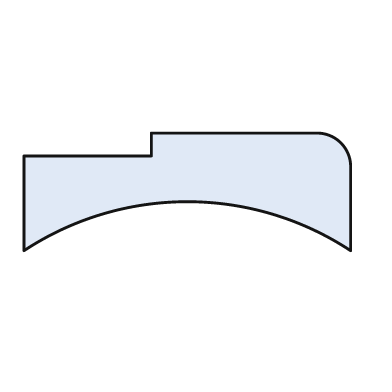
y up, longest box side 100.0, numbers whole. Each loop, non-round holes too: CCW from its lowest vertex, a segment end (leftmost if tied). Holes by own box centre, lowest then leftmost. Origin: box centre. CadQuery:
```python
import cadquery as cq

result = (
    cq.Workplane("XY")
    .moveTo(-50.0, -18.0)
    .threePointArc((0.0, -3.0), (50.0, -18.0))
    .lineTo(50.0, 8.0)
    .threePointArc((47.0, 15.0), (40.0, 18.0))
    .lineTo(-11.0, 18.0)
    .lineTo(-11.0, 11.0)
    .lineTo(-50.0, 11.0)
    .close()
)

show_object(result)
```